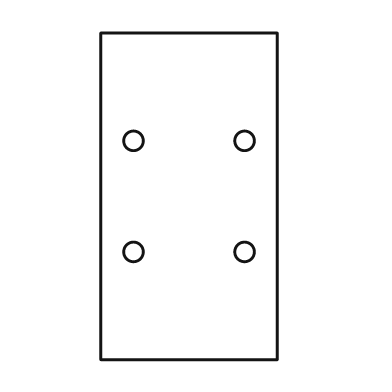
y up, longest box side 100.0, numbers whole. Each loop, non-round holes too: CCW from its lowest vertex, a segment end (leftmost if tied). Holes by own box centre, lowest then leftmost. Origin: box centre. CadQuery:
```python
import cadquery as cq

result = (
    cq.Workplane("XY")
    .moveTo(-27.0, -50.0)
    .lineTo(27.0, -50.0)
    .lineTo(27.0, 50.0)
    .lineTo(-27.0, 50.0)
    .close()
    .moveTo(-17.0, -17.0)
    .circle(3.0)
    .moveTo(17.0, -17.0)
    .circle(3.0)
    .moveTo(-17.0, 17.0)
    .circle(3.0)
    .moveTo(17.0, 17.0)
    .circle(3.0)
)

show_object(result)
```